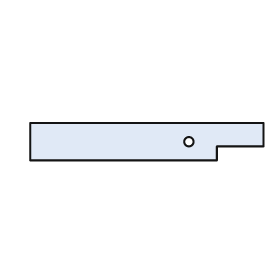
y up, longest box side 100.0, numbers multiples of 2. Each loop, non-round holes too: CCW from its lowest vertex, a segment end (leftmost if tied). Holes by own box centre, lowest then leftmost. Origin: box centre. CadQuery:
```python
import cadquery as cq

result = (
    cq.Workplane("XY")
    .moveTo(-50.0, -8.0)
    .lineTo(30.0, -8.0)
    .lineTo(30.0, -2.0)
    .lineTo(50.0, -2.0)
    .lineTo(50.0, 8.0)
    .lineTo(-50.0, 8.0)
    .close()
    .moveTo(18.0, 0.0)
    .circle(2.0)
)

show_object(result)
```